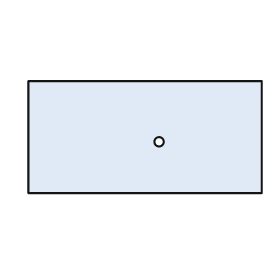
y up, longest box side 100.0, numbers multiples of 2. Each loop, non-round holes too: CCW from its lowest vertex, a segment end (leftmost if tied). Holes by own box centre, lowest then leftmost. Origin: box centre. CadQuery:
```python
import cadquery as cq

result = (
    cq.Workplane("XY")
    .moveTo(-50.0, -24.0)
    .lineTo(50.0, -24.0)
    .lineTo(50.0, 24.0)
    .lineTo(-50.0, 24.0)
    .close()
    .moveTo(6.0, -2.0)
    .circle(2.0)
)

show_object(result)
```